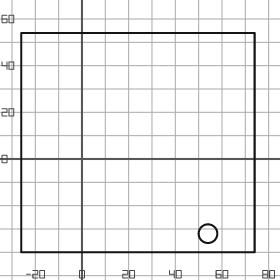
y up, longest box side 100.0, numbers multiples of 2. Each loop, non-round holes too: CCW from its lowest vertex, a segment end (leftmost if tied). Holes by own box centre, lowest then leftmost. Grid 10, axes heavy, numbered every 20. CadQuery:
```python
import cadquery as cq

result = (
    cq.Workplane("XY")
    .moveTo(-26.0, -40.0)
    .lineTo(74.0, -40.0)
    .lineTo(74.0, 54.0)
    .lineTo(-26.0, 54.0)
    .close()
    .moveTo(54.0, -32.0)
    .circle(4.0)
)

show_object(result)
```